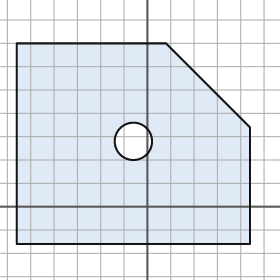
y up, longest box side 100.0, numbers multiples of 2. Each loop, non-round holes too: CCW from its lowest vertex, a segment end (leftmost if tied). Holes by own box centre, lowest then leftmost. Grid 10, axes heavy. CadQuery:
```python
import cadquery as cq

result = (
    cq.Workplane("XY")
    .moveTo(-56.0, -16.0)
    .lineTo(44.0, -16.0)
    .lineTo(44.0, 34.0)
    .lineTo(8.0, 70.0)
    .lineTo(-56.0, 70.0)
    .close()
    .moveTo(-6.0, 28.0)
    .circle(8.0)
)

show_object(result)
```